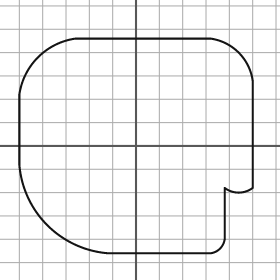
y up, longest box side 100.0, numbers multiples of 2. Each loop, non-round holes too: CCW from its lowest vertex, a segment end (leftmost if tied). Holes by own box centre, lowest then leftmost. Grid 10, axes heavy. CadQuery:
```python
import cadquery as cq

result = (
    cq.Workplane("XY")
    .moveTo(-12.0, -46.0)
    .lineTo(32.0, -46.0)
    .threePointArc((36.0, -44.0), (38.0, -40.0))
    .lineTo(38.0, -18.0)
    .threePointArc((44.0, -20.0), (50.0, -18.0))
    .lineTo(50.0, 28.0)
    .threePointArc((44.0, 40.0), (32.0, 46.0))
    .lineTo(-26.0, 46.0)
    .threePointArc((-42.0, 38.0), (-50.0, 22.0))
    .lineTo(-50.0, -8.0)
    .threePointArc((-38.0, -34.0), (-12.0, -46.0))
    .close()
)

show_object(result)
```